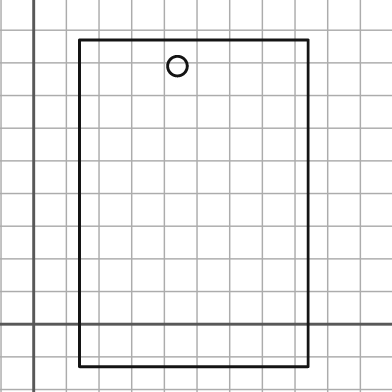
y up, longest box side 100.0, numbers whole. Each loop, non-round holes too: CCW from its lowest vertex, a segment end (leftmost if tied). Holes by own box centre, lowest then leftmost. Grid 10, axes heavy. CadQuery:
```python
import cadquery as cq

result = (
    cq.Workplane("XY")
    .moveTo(14.0, -13.0)
    .lineTo(84.0, -13.0)
    .lineTo(84.0, 87.0)
    .lineTo(14.0, 87.0)
    .close()
    .moveTo(44.0, 79.0)
    .circle(3.0)
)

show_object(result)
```